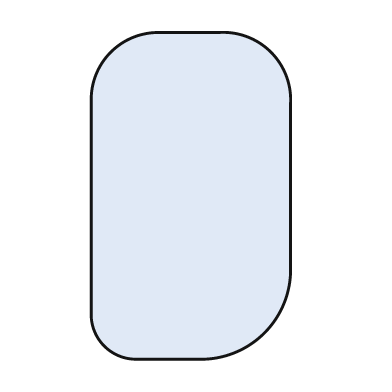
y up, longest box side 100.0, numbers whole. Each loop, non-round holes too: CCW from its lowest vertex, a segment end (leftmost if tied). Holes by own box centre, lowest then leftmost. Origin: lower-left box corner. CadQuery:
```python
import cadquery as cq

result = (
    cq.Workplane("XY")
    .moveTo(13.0, 0.0)
    .lineTo(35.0, 0.0)
    .threePointArc((53.0, 8.0), (61.0, 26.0))
    .lineTo(61.0, 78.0)
    .threePointArc((55.0, 94.0), (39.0, 100.0))
    .lineTo(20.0, 100.0)
    .threePointArc((6.0, 94.0), (0.0, 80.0))
    .lineTo(0.0, 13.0)
    .threePointArc((4.0, 4.0), (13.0, 0.0))
    .close()
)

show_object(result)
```